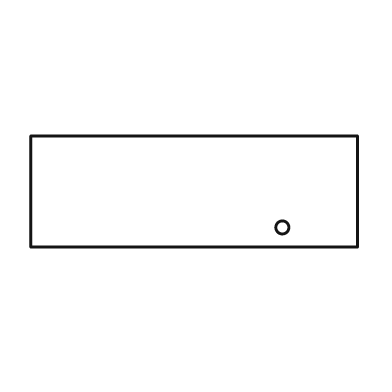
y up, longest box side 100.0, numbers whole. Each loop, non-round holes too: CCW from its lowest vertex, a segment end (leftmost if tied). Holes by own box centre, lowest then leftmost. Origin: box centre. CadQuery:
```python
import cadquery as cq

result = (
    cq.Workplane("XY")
    .moveTo(-50.0, -17.0)
    .lineTo(50.0, -17.0)
    .lineTo(50.0, 17.0)
    .lineTo(-50.0, 17.0)
    .close()
    .moveTo(27.0, -11.0)
    .circle(2.0)
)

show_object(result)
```